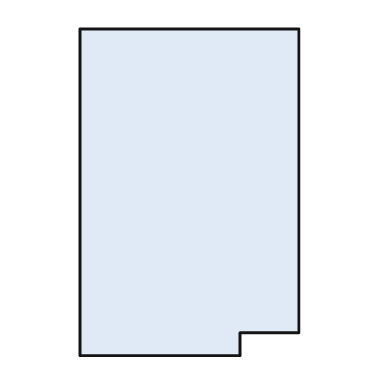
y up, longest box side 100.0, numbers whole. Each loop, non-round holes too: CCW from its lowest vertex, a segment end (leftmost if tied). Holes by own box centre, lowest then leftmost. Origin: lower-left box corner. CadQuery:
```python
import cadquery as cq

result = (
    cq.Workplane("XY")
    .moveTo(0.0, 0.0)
    .lineTo(49.0, 0.0)
    .lineTo(49.0, 7.0)
    .lineTo(67.0, 7.0)
    .lineTo(67.0, 100.0)
    .lineTo(0.0, 100.0)
    .close()
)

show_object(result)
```